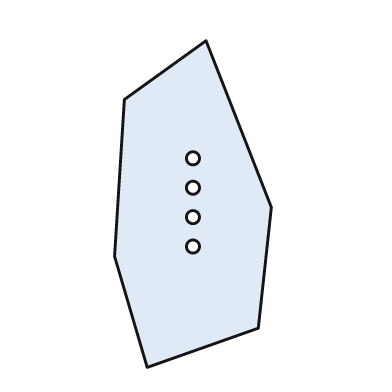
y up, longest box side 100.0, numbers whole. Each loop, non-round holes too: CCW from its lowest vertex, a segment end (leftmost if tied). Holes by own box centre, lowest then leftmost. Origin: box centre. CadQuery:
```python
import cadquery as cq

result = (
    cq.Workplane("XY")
    .moveTo(-14.0, -50.0)
    .lineTo(20.0, -38.0)
    .lineTo(24.0, -1.0)
    .lineTo(4.0, 50.0)
    .lineTo(-21.0, 32.0)
    .lineTo(-24.0, -16.0)
    .close()
    .moveTo(0.0, -13.0)
    .circle(2.0)
    .moveTo(0.0, -4.0)
    .circle(2.0)
    .moveTo(0.0, 5.0)
    .circle(2.0)
    .moveTo(0.0, 14.0)
    .circle(2.0)
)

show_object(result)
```